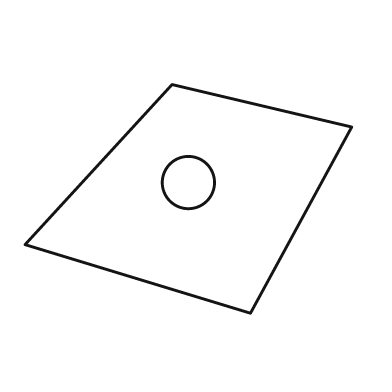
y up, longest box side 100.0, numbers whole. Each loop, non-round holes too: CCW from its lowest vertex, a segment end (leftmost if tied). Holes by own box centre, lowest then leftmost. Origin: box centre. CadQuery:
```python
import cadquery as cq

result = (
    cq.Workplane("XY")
    .moveTo(19.0, -35.0)
    .lineTo(50.0, 22.0)
    .lineTo(-5.0, 35.0)
    .lineTo(-50.0, -14.0)
    .close()
    .moveTo(0.0, 5.0)
    .circle(8.0)
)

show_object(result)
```